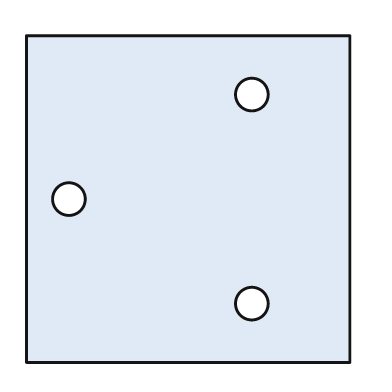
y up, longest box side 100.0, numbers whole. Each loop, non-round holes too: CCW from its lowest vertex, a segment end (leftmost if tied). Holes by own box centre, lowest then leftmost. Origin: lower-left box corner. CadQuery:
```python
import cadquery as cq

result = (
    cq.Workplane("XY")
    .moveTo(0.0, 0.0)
    .lineTo(99.0, 0.0)
    .lineTo(99.0, 100.0)
    .lineTo(0.0, 100.0)
    .close()
    .moveTo(69.0, 18.0)
    .circle(5.0)
    .moveTo(13.0, 50.0)
    .circle(5.0)
    .moveTo(69.0, 82.0)
    .circle(5.0)
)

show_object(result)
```